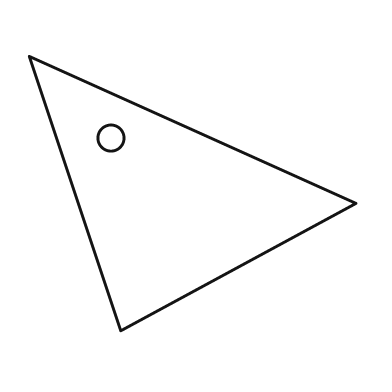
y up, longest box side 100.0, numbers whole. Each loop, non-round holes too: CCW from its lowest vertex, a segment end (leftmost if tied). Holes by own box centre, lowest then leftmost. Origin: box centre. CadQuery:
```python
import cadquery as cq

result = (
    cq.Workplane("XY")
    .moveTo(-22.0, -42.0)
    .lineTo(50.0, -3.0)
    .lineTo(-50.0, 42.0)
    .close()
    .moveTo(-25.0, 17.0)
    .circle(4.0)
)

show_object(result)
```